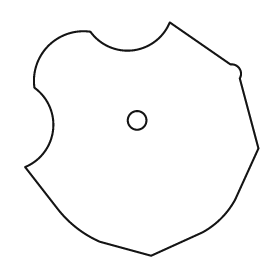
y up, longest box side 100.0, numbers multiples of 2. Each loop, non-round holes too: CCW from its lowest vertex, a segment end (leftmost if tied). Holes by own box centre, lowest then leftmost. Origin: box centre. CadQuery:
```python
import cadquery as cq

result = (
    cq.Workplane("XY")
    .moveTo(4.0, -50.0)
    .lineTo(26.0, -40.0)
    .threePointArc((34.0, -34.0), (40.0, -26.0))
    .lineTo(50.0, -4.0)
    .lineTo(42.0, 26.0)
    .threePointArc((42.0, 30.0), (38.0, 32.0))
    .lineTo(12.0, 50.0)
    .threePointArc((-4.0, 38.0), (-22.0, 46.0))
    .threePointArc((-40.0, 40.0), (-46.0, 22.0))
    .threePointArc((-38.0, 4.0), (-50.0, -12.0))
    .lineTo(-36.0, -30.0)
    .threePointArc((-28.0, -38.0), (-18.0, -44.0))
    .close()
    .moveTo(-2.0, 8.0)
    .circle(4.0)
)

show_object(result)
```